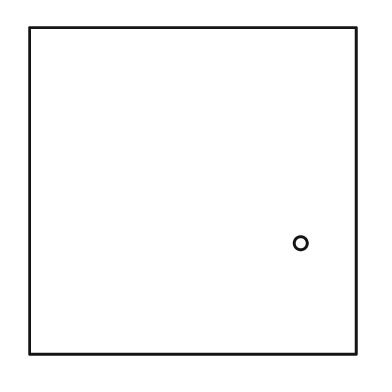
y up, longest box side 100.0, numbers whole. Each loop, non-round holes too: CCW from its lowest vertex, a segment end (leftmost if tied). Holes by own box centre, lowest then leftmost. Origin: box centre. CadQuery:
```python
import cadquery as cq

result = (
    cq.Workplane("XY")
    .moveTo(-50.0, -50.0)
    .lineTo(50.0, -50.0)
    .lineTo(50.0, 50.0)
    .lineTo(-50.0, 50.0)
    .close()
    .moveTo(33.0, -16.0)
    .circle(2.0)
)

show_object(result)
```